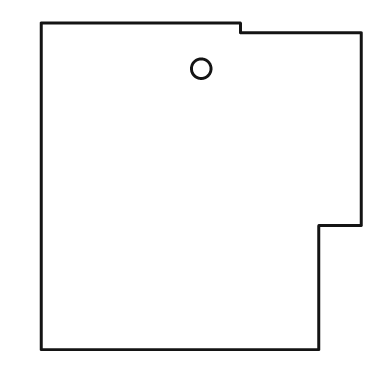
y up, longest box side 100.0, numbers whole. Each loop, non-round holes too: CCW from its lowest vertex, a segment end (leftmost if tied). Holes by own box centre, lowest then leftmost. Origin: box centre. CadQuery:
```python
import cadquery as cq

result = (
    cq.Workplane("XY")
    .moveTo(-49.0, -50.0)
    .lineTo(36.0, -50.0)
    .lineTo(36.0, -12.0)
    .lineTo(49.0, -12.0)
    .lineTo(49.0, 47.0)
    .lineTo(12.0, 47.0)
    .lineTo(12.0, 50.0)
    .lineTo(-49.0, 50.0)
    .close()
    .moveTo(0.0, 36.0)
    .circle(3.0)
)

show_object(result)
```